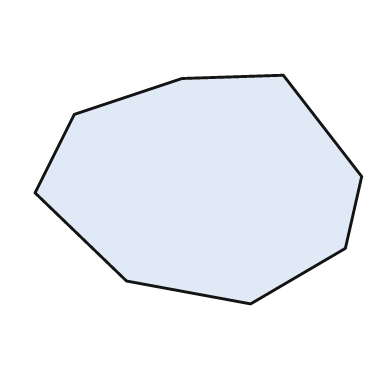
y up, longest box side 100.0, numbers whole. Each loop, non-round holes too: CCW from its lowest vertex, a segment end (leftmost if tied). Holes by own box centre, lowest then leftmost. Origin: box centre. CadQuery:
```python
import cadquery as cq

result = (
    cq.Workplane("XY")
    .moveTo(16.0, -35.0)
    .lineTo(45.0, -18.0)
    .lineTo(50.0, 4.0)
    .lineTo(26.0, 35.0)
    .lineTo(-5.0, 34.0)
    .lineTo(-38.0, 23.0)
    .lineTo(-50.0, -1.0)
    .lineTo(-22.0, -28.0)
    .close()
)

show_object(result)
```